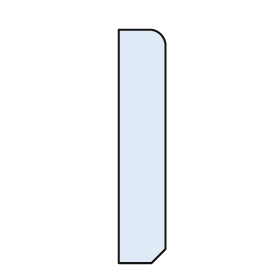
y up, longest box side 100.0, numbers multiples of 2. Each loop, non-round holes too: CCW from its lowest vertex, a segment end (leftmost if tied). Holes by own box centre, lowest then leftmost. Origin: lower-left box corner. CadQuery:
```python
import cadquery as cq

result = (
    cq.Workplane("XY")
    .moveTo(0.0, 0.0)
    .lineTo(14.0, 0.0)
    .lineTo(20.0, 6.0)
    .lineTo(20.0, 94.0)
    .threePointArc((18.0, 98.0), (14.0, 100.0))
    .lineTo(0.0, 100.0)
    .close()
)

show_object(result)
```